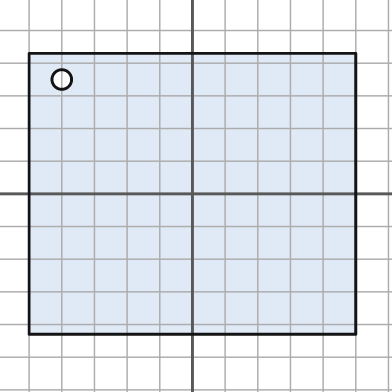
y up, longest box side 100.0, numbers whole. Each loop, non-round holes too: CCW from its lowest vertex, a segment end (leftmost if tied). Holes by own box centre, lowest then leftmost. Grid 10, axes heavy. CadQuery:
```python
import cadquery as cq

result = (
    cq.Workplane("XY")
    .moveTo(-50.0, -43.0)
    .lineTo(50.0, -43.0)
    .lineTo(50.0, 43.0)
    .lineTo(-50.0, 43.0)
    .close()
    .moveTo(-40.0, 35.0)
    .circle(3.0)
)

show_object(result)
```